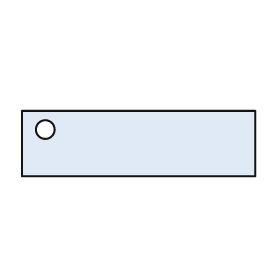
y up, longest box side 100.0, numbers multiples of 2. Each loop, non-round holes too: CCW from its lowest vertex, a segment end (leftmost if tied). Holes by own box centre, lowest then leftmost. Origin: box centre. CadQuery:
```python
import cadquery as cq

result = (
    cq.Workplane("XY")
    .moveTo(-50.0, -14.0)
    .lineTo(50.0, -14.0)
    .lineTo(50.0, 14.0)
    .lineTo(-50.0, 14.0)
    .close()
    .moveTo(-40.0, 6.0)
    .circle(4.0)
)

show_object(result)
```